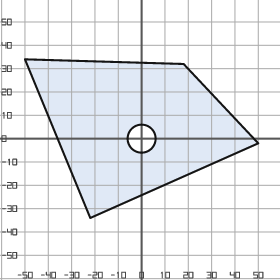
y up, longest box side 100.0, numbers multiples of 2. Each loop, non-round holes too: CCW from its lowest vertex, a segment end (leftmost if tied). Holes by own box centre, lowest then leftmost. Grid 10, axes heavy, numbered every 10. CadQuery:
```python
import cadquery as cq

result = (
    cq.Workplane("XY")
    .moveTo(-22.0, -34.0)
    .lineTo(50.0, -2.0)
    .lineTo(18.0, 32.0)
    .lineTo(-50.0, 34.0)
    .close()
    .moveTo(0.0, 0.0)
    .circle(6.0)
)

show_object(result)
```